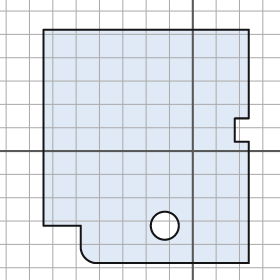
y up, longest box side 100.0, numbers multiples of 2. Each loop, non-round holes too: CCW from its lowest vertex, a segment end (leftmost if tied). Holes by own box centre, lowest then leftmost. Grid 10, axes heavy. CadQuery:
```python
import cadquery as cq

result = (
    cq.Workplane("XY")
    .moveTo(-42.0, -48.0)
    .lineTo(24.0, -48.0)
    .lineTo(24.0, 4.0)
    .lineTo(18.0, 4.0)
    .lineTo(18.0, 14.0)
    .lineTo(24.0, 14.0)
    .lineTo(24.0, 52.0)
    .lineTo(-64.0, 52.0)
    .lineTo(-64.0, -32.0)
    .lineTo(-48.0, -32.0)
    .lineTo(-48.0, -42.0)
    .threePointArc((-46.0, -46.0), (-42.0, -48.0))
    .close()
    .moveTo(-12.0, -32.0)
    .circle(6.0)
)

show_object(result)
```